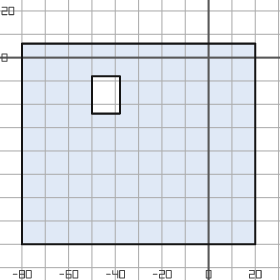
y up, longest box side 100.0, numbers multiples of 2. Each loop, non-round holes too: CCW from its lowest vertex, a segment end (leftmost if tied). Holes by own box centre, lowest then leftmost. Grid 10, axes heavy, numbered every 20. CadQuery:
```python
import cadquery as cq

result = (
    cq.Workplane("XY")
    .moveTo(-80.0, -80.0)
    .lineTo(20.0, -80.0)
    .lineTo(20.0, 6.0)
    .lineTo(-80.0, 6.0)
    .close()
    .moveTo(-50.0, -24.0)
    .lineTo(-38.0, -24.0)
    .lineTo(-38.0, -8.0)
    .lineTo(-50.0, -8.0)
    .close()
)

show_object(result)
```